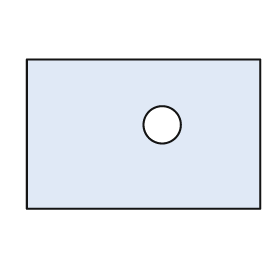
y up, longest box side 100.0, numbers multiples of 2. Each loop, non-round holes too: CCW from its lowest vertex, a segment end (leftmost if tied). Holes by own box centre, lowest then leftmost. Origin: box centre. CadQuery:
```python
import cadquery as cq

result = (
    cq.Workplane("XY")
    .moveTo(-50.0, -32.0)
    .lineTo(50.0, -32.0)
    .lineTo(50.0, 32.0)
    .lineTo(-50.0, 32.0)
    .close()
    .moveTo(8.0, 4.0)
    .circle(8.0)
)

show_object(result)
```